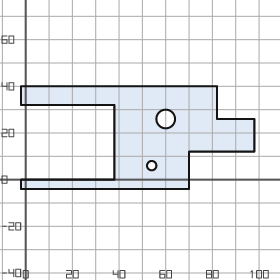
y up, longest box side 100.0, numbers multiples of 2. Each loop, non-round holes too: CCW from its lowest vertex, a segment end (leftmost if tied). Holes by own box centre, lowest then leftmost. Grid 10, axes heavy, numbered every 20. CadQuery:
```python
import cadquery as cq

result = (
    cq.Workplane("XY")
    .moveTo(-2.0, -4.0)
    .lineTo(70.0, -4.0)
    .lineTo(70.0, 12.0)
    .lineTo(98.0, 12.0)
    .lineTo(98.0, 26.0)
    .lineTo(82.0, 26.0)
    .lineTo(82.0, 40.0)
    .lineTo(-2.0, 40.0)
    .lineTo(-2.0, 32.0)
    .lineTo(38.0, 32.0)
    .lineTo(38.0, 0.0)
    .lineTo(-2.0, 0.0)
    .close()
    .moveTo(54.0, 6.0)
    .circle(2.0)
    .moveTo(60.0, 26.0)
    .circle(4.0)
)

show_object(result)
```